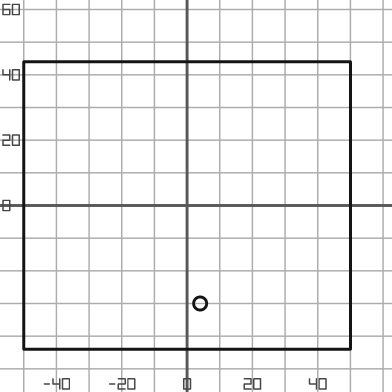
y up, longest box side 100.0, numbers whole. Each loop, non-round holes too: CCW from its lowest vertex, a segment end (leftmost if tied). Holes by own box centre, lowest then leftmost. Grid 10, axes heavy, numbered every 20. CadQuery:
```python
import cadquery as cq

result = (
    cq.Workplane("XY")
    .moveTo(-50.0, -44.0)
    .lineTo(50.0, -44.0)
    .lineTo(50.0, 44.0)
    .lineTo(-50.0, 44.0)
    .close()
    .moveTo(4.0, -30.0)
    .circle(2.0)
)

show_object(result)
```